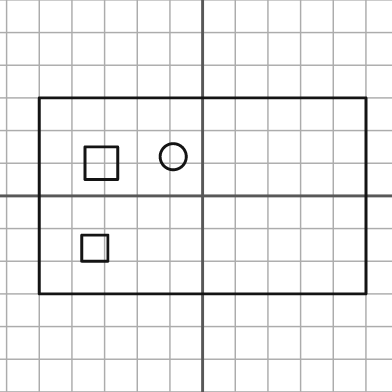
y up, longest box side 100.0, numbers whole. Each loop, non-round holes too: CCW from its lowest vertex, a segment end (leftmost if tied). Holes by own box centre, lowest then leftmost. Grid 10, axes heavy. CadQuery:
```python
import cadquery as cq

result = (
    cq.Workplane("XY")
    .moveTo(-50.0, -30.0)
    .lineTo(50.0, -30.0)
    .lineTo(50.0, 30.0)
    .lineTo(-50.0, 30.0)
    .close()
    .moveTo(-37.0, -20.0)
    .lineTo(-29.0, -20.0)
    .lineTo(-29.0, -12.0)
    .lineTo(-37.0, -12.0)
    .close()
    .moveTo(-36.0, 5.0)
    .lineTo(-26.0, 5.0)
    .lineTo(-26.0, 15.0)
    .lineTo(-36.0, 15.0)
    .close()
    .moveTo(-9.0, 12.0)
    .circle(4.0)
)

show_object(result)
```